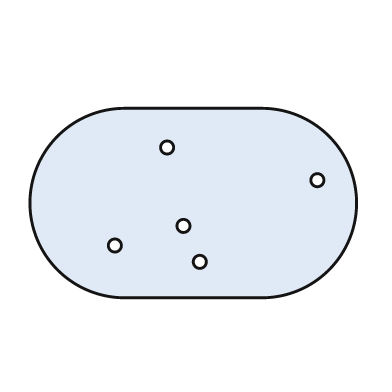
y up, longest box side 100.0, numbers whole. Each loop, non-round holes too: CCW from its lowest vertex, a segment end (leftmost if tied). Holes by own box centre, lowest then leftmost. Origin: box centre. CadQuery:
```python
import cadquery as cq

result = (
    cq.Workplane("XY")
    .moveTo(-21.0, -29.0)
    .lineTo(21.0, -29.0)
    .threePointArc((50.0, 0.0), (21.0, 29.0))
    .lineTo(-21.0, 29.0)
    .threePointArc((-50.0, 0.0), (-21.0, -29.0))
    .close()
    .moveTo(2.0, -18.0)
    .circle(2.0)
    .moveTo(-24.0, -13.0)
    .circle(2.0)
    .moveTo(-3.0, -7.0)
    .circle(2.0)
    .moveTo(38.0, 7.0)
    .circle(2.0)
    .moveTo(-8.0, 17.0)
    .circle(2.0)
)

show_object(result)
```